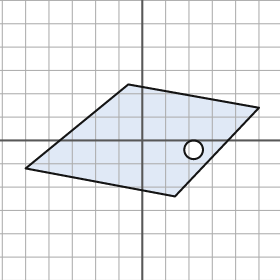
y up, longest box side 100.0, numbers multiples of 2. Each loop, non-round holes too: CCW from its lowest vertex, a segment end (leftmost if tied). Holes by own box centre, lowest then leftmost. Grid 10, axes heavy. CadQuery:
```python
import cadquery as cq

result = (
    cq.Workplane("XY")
    .moveTo(14.0, -24.0)
    .lineTo(50.0, 14.0)
    .lineTo(-6.0, 24.0)
    .lineTo(-50.0, -12.0)
    .close()
    .moveTo(22.0, -4.0)
    .circle(4.0)
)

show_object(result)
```